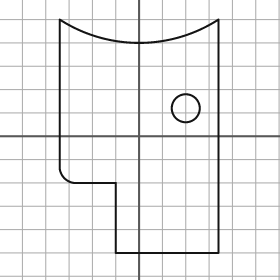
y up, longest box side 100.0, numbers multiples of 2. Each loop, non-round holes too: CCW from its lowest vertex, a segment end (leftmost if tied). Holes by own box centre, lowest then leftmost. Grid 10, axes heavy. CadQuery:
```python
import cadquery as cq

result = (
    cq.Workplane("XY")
    .moveTo(-10.0, -50.0)
    .lineTo(34.0, -50.0)
    .lineTo(34.0, 50.0)
    .threePointArc((0.0, 40.0), (-34.0, 50.0))
    .lineTo(-34.0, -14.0)
    .threePointArc((-32.0, -18.0), (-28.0, -20.0))
    .lineTo(-10.0, -20.0)
    .close()
    .moveTo(20.0, 12.0)
    .circle(6.0)
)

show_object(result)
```